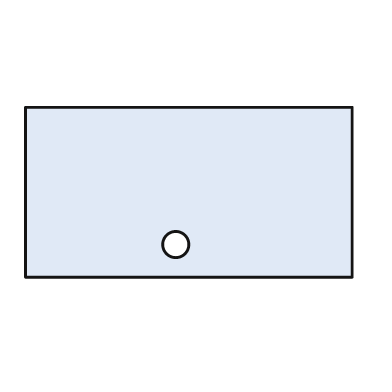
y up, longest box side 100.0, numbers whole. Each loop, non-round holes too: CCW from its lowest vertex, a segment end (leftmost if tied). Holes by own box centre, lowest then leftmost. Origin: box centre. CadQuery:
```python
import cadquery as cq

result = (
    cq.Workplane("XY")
    .moveTo(-50.0, -26.0)
    .lineTo(50.0, -26.0)
    .lineTo(50.0, 26.0)
    .lineTo(-50.0, 26.0)
    .close()
    .moveTo(-4.0, -16.0)
    .circle(4.0)
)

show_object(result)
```